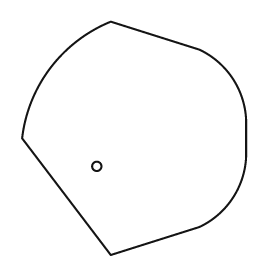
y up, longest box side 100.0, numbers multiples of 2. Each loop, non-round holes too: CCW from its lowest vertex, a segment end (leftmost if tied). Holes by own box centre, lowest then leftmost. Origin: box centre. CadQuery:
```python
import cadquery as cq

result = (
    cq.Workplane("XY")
    .moveTo(-10.0, -50.0)
    .lineTo(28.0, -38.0)
    .threePointArc((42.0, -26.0), (48.0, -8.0))
    .lineTo(48.0, 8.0)
    .threePointArc((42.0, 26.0), (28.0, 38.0))
    .lineTo(-10.0, 50.0)
    .threePointArc((-36.0, 30.0), (-48.0, 0.0))
    .close()
    .moveTo(-16.0, -12.0)
    .circle(2.0)
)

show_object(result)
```